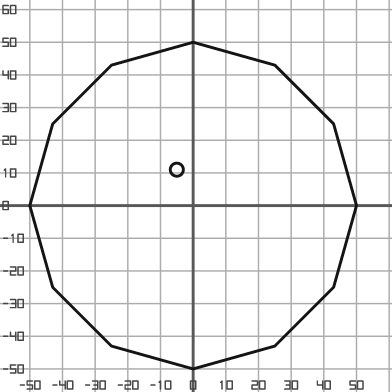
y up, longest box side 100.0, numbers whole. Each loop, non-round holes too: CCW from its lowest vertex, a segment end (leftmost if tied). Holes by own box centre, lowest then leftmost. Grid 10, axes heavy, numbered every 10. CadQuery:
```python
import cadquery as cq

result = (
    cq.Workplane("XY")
    .moveTo(0.0, -50.0)
    .lineTo(25.0, -43.0)
    .lineTo(43.0, -25.0)
    .lineTo(50.0, 0.0)
    .lineTo(43.0, 25.0)
    .lineTo(25.0, 43.0)
    .lineTo(0.0, 50.0)
    .lineTo(-25.0, 43.0)
    .lineTo(-43.0, 25.0)
    .lineTo(-50.0, 0.0)
    .lineTo(-43.0, -25.0)
    .lineTo(-25.0, -43.0)
    .close()
    .moveTo(-5.0, 11.0)
    .circle(2.0)
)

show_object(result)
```